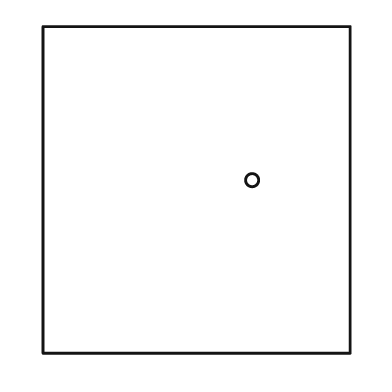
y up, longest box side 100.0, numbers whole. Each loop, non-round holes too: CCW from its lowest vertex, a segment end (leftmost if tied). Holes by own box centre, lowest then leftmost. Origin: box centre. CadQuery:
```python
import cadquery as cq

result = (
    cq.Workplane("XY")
    .moveTo(-47.0, -50.0)
    .lineTo(47.0, -50.0)
    .lineTo(47.0, 50.0)
    .lineTo(-47.0, 50.0)
    .close()
    .moveTo(17.0, 3.0)
    .circle(2.0)
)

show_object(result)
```